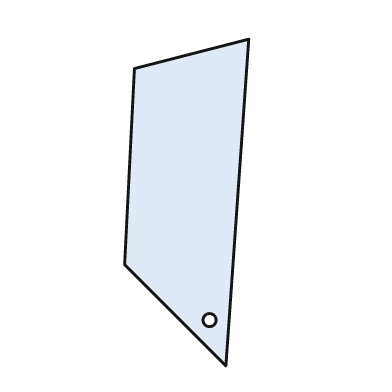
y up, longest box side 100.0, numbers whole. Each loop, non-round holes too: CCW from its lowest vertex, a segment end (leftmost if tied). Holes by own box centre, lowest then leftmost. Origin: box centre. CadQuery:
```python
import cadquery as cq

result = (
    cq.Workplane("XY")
    .moveTo(12.0, -50.0)
    .lineTo(19.0, 50.0)
    .lineTo(-16.0, 41.0)
    .lineTo(-19.0, -19.0)
    .close()
    .moveTo(7.0, -36.0)
    .circle(2.0)
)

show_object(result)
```